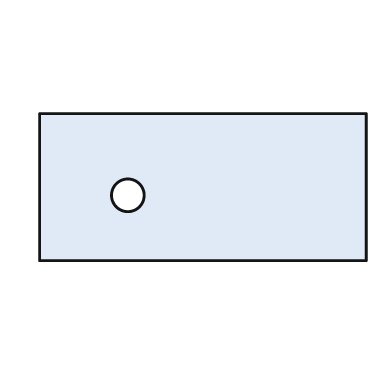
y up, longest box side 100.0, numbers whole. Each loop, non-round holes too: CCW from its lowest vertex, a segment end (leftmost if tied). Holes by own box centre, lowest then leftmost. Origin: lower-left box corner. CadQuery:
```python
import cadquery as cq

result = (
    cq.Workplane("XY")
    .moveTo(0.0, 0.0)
    .lineTo(100.0, 0.0)
    .lineTo(100.0, 45.0)
    .lineTo(0.0, 45.0)
    .close()
    .moveTo(27.0, 20.0)
    .circle(5.0)
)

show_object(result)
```